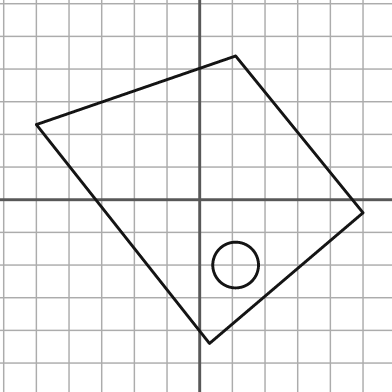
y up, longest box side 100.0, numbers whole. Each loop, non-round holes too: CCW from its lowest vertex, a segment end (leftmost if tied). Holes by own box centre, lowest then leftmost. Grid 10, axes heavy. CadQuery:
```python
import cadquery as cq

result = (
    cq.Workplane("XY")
    .moveTo(3.0, -44.0)
    .lineTo(50.0, -4.0)
    .lineTo(11.0, 44.0)
    .lineTo(-50.0, 23.0)
    .close()
    .moveTo(11.0, -20.0)
    .circle(7.0)
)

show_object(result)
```